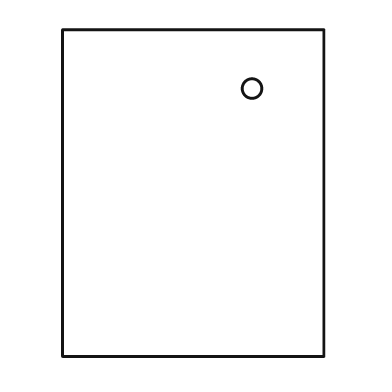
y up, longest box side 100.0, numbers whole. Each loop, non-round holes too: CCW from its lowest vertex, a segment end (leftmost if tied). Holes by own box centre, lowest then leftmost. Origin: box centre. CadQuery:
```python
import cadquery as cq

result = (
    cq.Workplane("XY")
    .moveTo(-40.0, -50.0)
    .lineTo(40.0, -50.0)
    .lineTo(40.0, 50.0)
    .lineTo(-40.0, 50.0)
    .close()
    .moveTo(18.0, 32.0)
    .circle(3.0)
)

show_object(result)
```